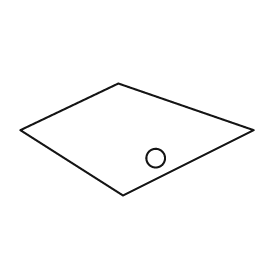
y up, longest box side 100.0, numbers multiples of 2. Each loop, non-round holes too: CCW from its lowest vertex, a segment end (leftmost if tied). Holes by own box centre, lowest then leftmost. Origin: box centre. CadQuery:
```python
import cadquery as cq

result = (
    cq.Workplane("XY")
    .moveTo(-6.0, -24.0)
    .lineTo(50.0, 4.0)
    .lineTo(-8.0, 24.0)
    .lineTo(-50.0, 4.0)
    .close()
    .moveTo(8.0, -8.0)
    .circle(4.0)
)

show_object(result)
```